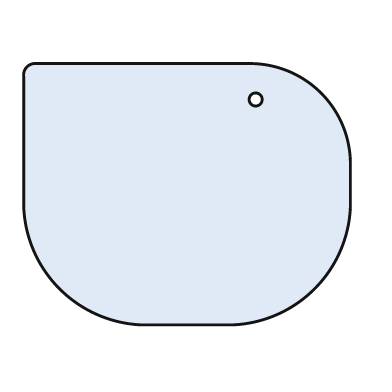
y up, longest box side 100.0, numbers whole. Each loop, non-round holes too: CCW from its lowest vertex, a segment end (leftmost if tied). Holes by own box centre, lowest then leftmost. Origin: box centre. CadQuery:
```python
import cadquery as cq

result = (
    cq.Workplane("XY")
    .moveTo(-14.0, -40.0)
    .lineTo(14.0, -40.0)
    .threePointArc((39.0, -29.0), (50.0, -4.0))
    .lineTo(50.0, 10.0)
    .threePointArc((41.0, 31.0), (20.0, 40.0))
    .lineTo(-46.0, 40.0)
    .threePointArc((-49.0, 39.0), (-50.0, 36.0))
    .lineTo(-50.0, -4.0)
    .threePointArc((-39.0, -29.0), (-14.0, -40.0))
    .close()
    .moveTo(21.0, 29.0)
    .circle(2.0)
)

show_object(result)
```